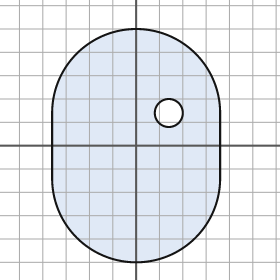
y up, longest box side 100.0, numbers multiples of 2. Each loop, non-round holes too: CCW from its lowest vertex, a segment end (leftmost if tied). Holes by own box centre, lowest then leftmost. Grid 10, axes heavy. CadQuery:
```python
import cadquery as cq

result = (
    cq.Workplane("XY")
    .moveTo(-36.0, -14.0)
    .threePointArc((0.0, -50.0), (36.0, -14.0))
    .lineTo(36.0, 14.0)
    .threePointArc((0.0, 50.0), (-36.0, 14.0))
    .close()
    .moveTo(14.0, 14.0)
    .circle(6.0)
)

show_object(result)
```